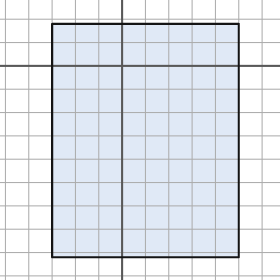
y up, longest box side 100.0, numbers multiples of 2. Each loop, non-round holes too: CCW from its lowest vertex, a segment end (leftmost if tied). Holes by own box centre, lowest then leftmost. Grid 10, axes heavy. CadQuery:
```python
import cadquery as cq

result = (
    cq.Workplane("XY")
    .moveTo(-30.0, -82.0)
    .lineTo(50.0, -82.0)
    .lineTo(50.0, 18.0)
    .lineTo(-30.0, 18.0)
    .close()
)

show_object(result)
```